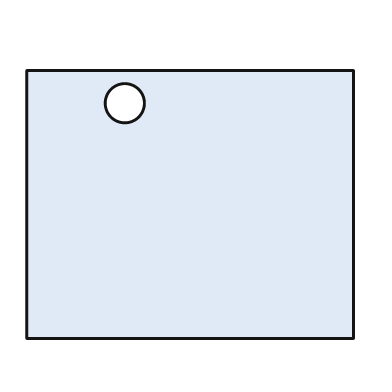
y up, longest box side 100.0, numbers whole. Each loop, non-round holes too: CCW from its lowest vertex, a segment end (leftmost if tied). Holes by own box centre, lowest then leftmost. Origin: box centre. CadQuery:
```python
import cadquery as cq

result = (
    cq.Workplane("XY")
    .moveTo(-50.0, -41.0)
    .lineTo(50.0, -41.0)
    .lineTo(50.0, 41.0)
    .lineTo(-50.0, 41.0)
    .close()
    .moveTo(-20.0, 31.0)
    .circle(6.0)
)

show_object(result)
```